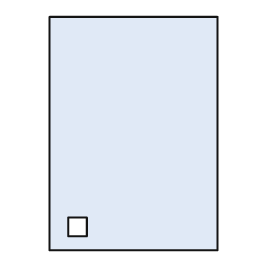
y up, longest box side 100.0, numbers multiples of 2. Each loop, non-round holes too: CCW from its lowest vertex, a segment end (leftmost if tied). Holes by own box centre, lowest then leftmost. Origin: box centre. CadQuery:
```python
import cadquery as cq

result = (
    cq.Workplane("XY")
    .moveTo(-36.0, -50.0)
    .lineTo(36.0, -50.0)
    .lineTo(36.0, 50.0)
    .lineTo(-36.0, 50.0)
    .close()
    .moveTo(-28.0, -44.0)
    .lineTo(-20.0, -44.0)
    .lineTo(-20.0, -36.0)
    .lineTo(-28.0, -36.0)
    .close()
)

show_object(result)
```